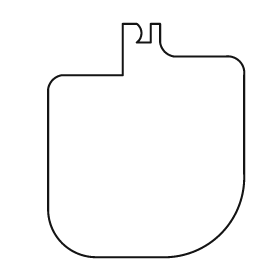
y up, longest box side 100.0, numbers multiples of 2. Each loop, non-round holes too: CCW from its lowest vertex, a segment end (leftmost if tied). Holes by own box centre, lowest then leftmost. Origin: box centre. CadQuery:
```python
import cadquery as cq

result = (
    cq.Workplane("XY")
    .moveTo(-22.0, -50.0)
    .lineTo(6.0, -50.0)
    .threePointArc((32.0, -40.0), (42.0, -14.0))
    .lineTo(42.0, 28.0)
    .threePointArc((40.0, 34.0), (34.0, 36.0))
    .lineTo(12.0, 36.0)
    .threePointArc((8.0, 38.0), (6.0, 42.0))
    .lineTo(6.0, 50.0)
    .lineTo(2.0, 50.0)
    .lineTo(2.0, 42.0)
    .lineTo(-4.0, 42.0)
    .threePointArc((-2.0, 46.0), (-4.0, 50.0))
    .lineTo(-10.0, 50.0)
    .lineTo(-10.0, 28.0)
    .lineTo(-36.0, 28.0)
    .threePointArc((-40.0, 26.0), (-42.0, 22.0))
    .lineTo(-42.0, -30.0)
    .threePointArc((-36.0, -44.0), (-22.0, -50.0))
    .close()
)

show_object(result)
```